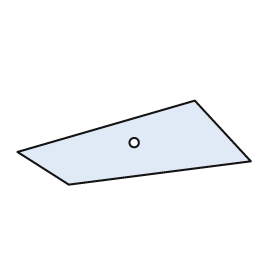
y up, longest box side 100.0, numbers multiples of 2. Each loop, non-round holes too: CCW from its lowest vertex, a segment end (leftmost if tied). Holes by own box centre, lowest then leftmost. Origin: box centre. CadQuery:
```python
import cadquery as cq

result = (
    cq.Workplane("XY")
    .moveTo(-28.0, -18.0)
    .lineTo(50.0, -8.0)
    .lineTo(26.0, 18.0)
    .lineTo(-50.0, -4.0)
    .close()
    .moveTo(0.0, 0.0)
    .circle(2.0)
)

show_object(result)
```